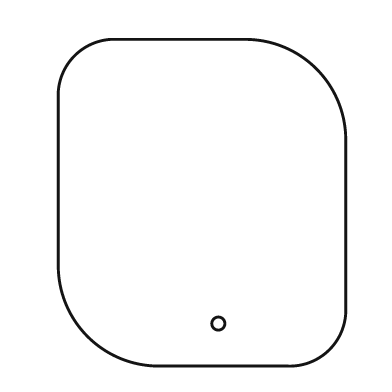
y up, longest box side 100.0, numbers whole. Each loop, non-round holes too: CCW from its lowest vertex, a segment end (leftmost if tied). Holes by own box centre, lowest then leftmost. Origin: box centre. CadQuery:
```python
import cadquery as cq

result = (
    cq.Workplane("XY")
    .moveTo(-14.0, -50.0)
    .lineTo(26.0, -50.0)
    .threePointArc((39.0, -45.0), (44.0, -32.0))
    .lineTo(44.0, 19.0)
    .threePointArc((35.0, 41.0), (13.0, 50.0))
    .lineTo(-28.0, 50.0)
    .threePointArc((-39.0, 45.0), (-44.0, 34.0))
    .lineTo(-44.0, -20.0)
    .threePointArc((-35.0, -41.0), (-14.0, -50.0))
    .close()
    .moveTo(5.0, -37.0)
    .circle(2.0)
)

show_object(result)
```